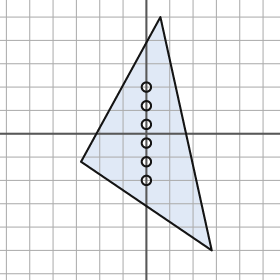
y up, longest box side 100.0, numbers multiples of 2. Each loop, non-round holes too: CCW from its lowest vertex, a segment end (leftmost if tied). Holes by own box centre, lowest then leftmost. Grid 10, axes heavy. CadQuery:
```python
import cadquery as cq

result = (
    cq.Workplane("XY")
    .moveTo(28.0, -50.0)
    .lineTo(6.0, 50.0)
    .lineTo(-28.0, -12.0)
    .close()
    .moveTo(0.0, -20.0)
    .circle(2.0)
    .moveTo(0.0, -12.0)
    .circle(2.0)
    .moveTo(0.0, -4.0)
    .circle(2.0)
    .moveTo(0.0, 4.0)
    .circle(2.0)
    .moveTo(0.0, 12.0)
    .circle(2.0)
    .moveTo(0.0, 20.0)
    .circle(2.0)
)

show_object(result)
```